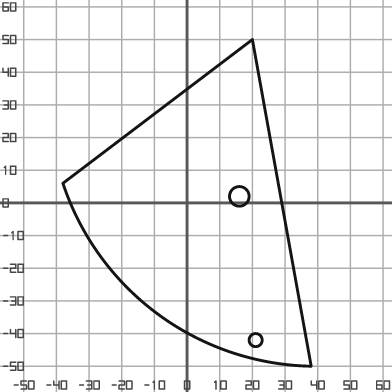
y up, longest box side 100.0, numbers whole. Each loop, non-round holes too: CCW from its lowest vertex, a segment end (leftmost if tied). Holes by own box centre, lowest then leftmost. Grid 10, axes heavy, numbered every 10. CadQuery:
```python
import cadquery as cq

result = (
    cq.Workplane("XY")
    .moveTo(38.0, -50.0)
    .lineTo(20.0, 50.0)
    .lineTo(-38.0, 6.0)
    .threePointArc((-9.0, -34.0), (38.0, -50.0))
    .close()
    .moveTo(21.0, -42.0)
    .circle(2.0)
    .moveTo(16.0, 2.0)
    .circle(3.0)
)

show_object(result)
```